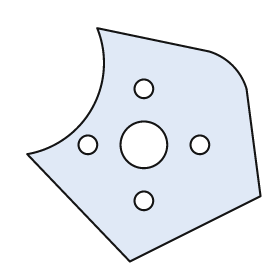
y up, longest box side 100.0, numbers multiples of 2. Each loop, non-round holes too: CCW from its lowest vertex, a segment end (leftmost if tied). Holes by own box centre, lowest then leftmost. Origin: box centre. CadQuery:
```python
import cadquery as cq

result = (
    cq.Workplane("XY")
    .moveTo(-6.0, -50.0)
    .lineTo(50.0, -22.0)
    .lineTo(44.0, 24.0)
    .threePointArc((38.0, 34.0), (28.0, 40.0))
    .lineTo(-20.0, 50.0)
    .threePointArc((-22.0, 16.0), (-50.0, -4.0))
    .close()
    .moveTo(0.0, -24.0)
    .circle(4.0)
    .moveTo(-24.0, 0.0)
    .circle(4.0)
    .moveTo(0.0, 0.0)
    .circle(10.0)
    .moveTo(24.0, 0.0)
    .circle(4.0)
    .moveTo(0.0, 24.0)
    .circle(4.0)
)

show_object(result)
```